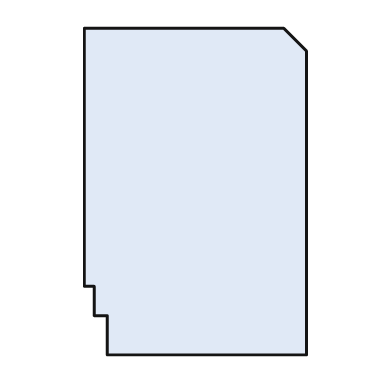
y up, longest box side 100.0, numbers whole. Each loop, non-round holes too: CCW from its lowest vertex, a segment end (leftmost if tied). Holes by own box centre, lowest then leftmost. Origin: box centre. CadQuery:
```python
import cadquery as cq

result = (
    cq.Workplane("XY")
    .moveTo(-27.0, -50.0)
    .lineTo(34.0, -50.0)
    .lineTo(34.0, 43.0)
    .lineTo(27.0, 50.0)
    .lineTo(-34.0, 50.0)
    .lineTo(-34.0, -29.0)
    .lineTo(-31.0, -29.0)
    .lineTo(-31.0, -38.0)
    .lineTo(-27.0, -38.0)
    .close()
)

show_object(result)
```